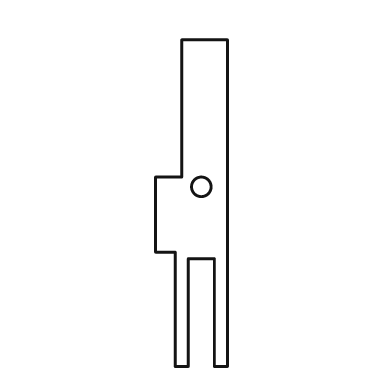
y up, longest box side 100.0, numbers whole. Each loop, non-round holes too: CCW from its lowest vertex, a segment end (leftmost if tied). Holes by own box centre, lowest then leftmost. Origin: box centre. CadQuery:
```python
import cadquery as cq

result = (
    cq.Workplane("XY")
    .moveTo(-5.0, -50.0)
    .lineTo(-1.0, -50.0)
    .lineTo(-1.0, -17.0)
    .lineTo(7.0, -17.0)
    .lineTo(7.0, -50.0)
    .lineTo(11.0, -50.0)
    .lineTo(11.0, 50.0)
    .lineTo(-3.0, 50.0)
    .lineTo(-3.0, 8.0)
    .lineTo(-11.0, 8.0)
    .lineTo(-11.0, -15.0)
    .lineTo(-5.0, -15.0)
    .close()
    .moveTo(3.0, 5.0)
    .circle(3.0)
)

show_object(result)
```